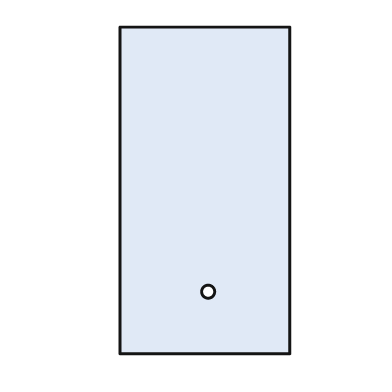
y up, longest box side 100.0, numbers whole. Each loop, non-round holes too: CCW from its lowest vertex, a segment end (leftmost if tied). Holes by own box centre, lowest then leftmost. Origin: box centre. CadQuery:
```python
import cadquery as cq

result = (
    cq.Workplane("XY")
    .moveTo(-26.0, -50.0)
    .lineTo(26.0, -50.0)
    .lineTo(26.0, 50.0)
    .lineTo(-26.0, 50.0)
    .close()
    .moveTo(1.0, -31.0)
    .circle(2.0)
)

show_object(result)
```